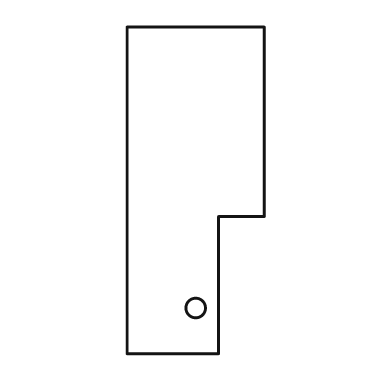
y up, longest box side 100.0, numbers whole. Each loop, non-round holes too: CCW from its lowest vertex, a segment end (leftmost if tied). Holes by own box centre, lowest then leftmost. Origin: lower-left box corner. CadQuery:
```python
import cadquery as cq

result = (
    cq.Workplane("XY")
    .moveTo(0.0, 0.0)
    .lineTo(28.0, 0.0)
    .lineTo(28.0, 42.0)
    .lineTo(42.0, 42.0)
    .lineTo(42.0, 100.0)
    .lineTo(0.0, 100.0)
    .close()
    .moveTo(21.0, 14.0)
    .circle(3.0)
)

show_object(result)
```